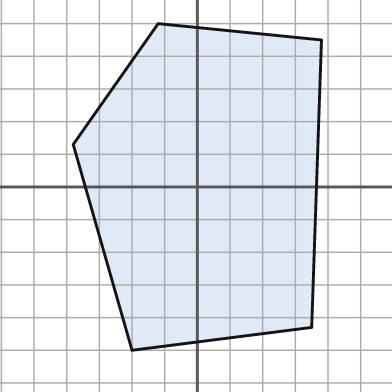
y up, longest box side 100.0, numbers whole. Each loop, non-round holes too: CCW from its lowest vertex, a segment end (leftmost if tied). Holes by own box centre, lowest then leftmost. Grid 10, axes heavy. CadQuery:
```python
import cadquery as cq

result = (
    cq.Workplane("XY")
    .moveTo(-20.0, -50.0)
    .lineTo(35.0, -43.0)
    .lineTo(38.0, 45.0)
    .lineTo(-12.0, 50.0)
    .lineTo(-38.0, 13.0)
    .close()
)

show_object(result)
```